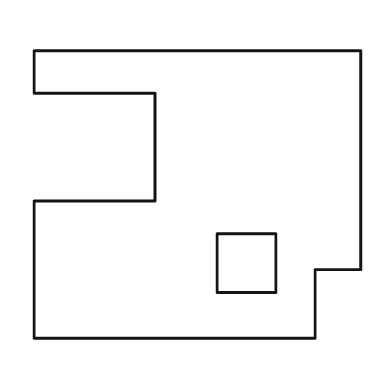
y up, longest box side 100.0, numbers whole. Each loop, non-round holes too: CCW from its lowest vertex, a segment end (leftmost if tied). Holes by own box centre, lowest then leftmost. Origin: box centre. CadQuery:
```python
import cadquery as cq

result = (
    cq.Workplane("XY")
    .moveTo(-50.0, -44.0)
    .lineTo(36.0, -44.0)
    .lineTo(36.0, -23.0)
    .lineTo(50.0, -23.0)
    .lineTo(50.0, 44.0)
    .lineTo(-50.0, 44.0)
    .lineTo(-50.0, 31.0)
    .lineTo(-13.0, 31.0)
    .lineTo(-13.0, -2.0)
    .lineTo(-50.0, -2.0)
    .close()
    .moveTo(6.0, -30.0)
    .lineTo(24.0, -30.0)
    .lineTo(24.0, -12.0)
    .lineTo(6.0, -12.0)
    .close()
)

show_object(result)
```